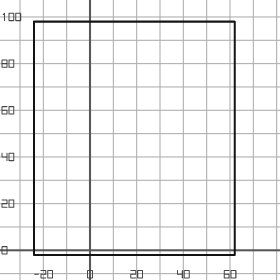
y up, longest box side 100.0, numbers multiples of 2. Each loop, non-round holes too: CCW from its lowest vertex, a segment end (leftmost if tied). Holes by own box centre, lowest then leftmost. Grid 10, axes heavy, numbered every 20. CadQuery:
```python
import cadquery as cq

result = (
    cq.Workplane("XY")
    .moveTo(-24.0, -2.0)
    .lineTo(62.0, -2.0)
    .lineTo(62.0, 98.0)
    .lineTo(-24.0, 98.0)
    .close()
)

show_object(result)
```